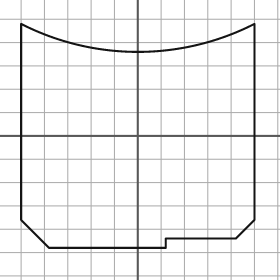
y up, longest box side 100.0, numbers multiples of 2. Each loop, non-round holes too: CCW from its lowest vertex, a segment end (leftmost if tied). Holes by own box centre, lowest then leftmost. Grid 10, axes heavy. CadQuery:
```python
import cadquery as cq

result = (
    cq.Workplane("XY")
    .moveTo(-38.0, -48.0)
    .lineTo(12.0, -48.0)
    .lineTo(12.0, -44.0)
    .lineTo(42.0, -44.0)
    .lineTo(50.0, -36.0)
    .lineTo(50.0, 48.0)
    .threePointArc((0.0, 36.0), (-50.0, 48.0))
    .lineTo(-50.0, -36.0)
    .close()
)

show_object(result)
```